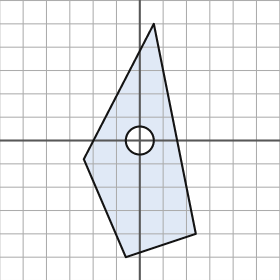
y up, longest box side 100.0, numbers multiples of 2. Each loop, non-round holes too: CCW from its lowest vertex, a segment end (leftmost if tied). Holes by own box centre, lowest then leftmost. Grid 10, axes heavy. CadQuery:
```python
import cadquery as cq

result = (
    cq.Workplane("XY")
    .moveTo(-6.0, -50.0)
    .lineTo(24.0, -40.0)
    .lineTo(6.0, 50.0)
    .lineTo(-24.0, -8.0)
    .close()
    .moveTo(0.0, 0.0)
    .circle(6.0)
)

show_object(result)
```